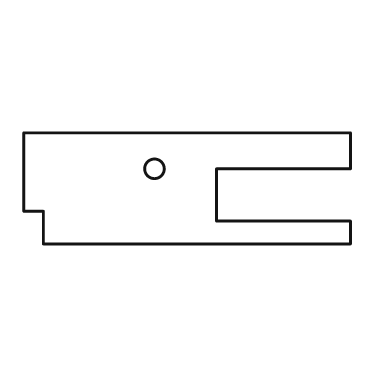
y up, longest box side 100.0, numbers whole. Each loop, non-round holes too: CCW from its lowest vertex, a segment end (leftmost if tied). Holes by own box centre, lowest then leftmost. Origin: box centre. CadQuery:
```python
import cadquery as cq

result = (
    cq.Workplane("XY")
    .moveTo(-44.0, -17.0)
    .lineTo(50.0, -17.0)
    .lineTo(50.0, -10.0)
    .lineTo(9.0, -10.0)
    .lineTo(9.0, 6.0)
    .lineTo(50.0, 6.0)
    .lineTo(50.0, 17.0)
    .lineTo(-50.0, 17.0)
    .lineTo(-50.0, -7.0)
    .lineTo(-44.0, -7.0)
    .close()
    .moveTo(-10.0, 6.0)
    .circle(3.0)
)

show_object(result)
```